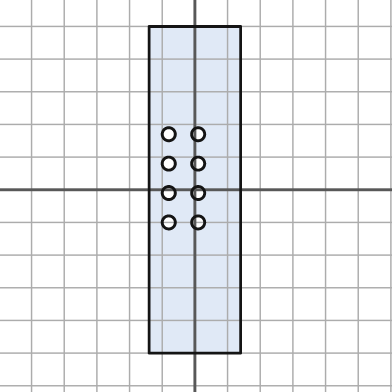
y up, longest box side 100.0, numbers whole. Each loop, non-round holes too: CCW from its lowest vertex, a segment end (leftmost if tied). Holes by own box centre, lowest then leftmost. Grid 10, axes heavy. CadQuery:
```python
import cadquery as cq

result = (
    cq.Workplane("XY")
    .moveTo(-14.0, -50.0)
    .lineTo(14.0, -50.0)
    .lineTo(14.0, 50.0)
    .lineTo(-14.0, 50.0)
    .close()
    .moveTo(-8.0, -10.0)
    .circle(2.0)
    .moveTo(1.0, -10.0)
    .circle(2.0)
    .moveTo(-8.0, -1.0)
    .circle(2.0)
    .moveTo(1.0, -1.0)
    .circle(2.0)
    .moveTo(-8.0, 8.0)
    .circle(2.0)
    .moveTo(1.0, 8.0)
    .circle(2.0)
    .moveTo(-8.0, 17.0)
    .circle(2.0)
    .moveTo(1.0, 17.0)
    .circle(2.0)
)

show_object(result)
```